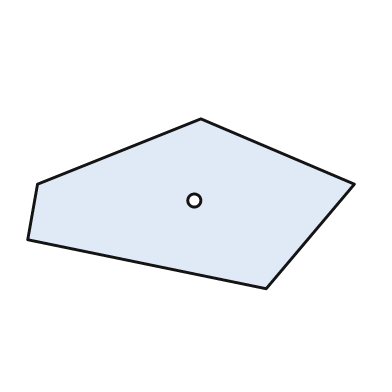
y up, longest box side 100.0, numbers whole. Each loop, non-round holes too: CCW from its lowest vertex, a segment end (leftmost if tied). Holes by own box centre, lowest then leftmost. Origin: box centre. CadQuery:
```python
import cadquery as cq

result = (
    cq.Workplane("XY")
    .moveTo(23.0, -26.0)
    .lineTo(50.0, 6.0)
    .lineTo(3.0, 26.0)
    .lineTo(-47.0, 6.0)
    .lineTo(-50.0, -11.0)
    .close()
    .moveTo(1.0, 1.0)
    .circle(2.0)
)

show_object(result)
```